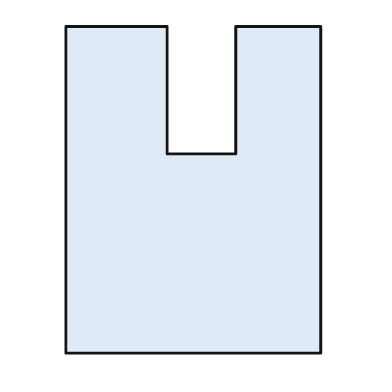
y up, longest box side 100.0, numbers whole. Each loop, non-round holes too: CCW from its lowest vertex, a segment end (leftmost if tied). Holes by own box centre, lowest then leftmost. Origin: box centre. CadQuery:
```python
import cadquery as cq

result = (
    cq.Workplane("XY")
    .moveTo(-39.0, -50.0)
    .lineTo(39.0, -50.0)
    .lineTo(39.0, 50.0)
    .lineTo(13.0, 50.0)
    .lineTo(13.0, 11.0)
    .lineTo(-8.0, 11.0)
    .lineTo(-8.0, 50.0)
    .lineTo(-39.0, 50.0)
    .close()
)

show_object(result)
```